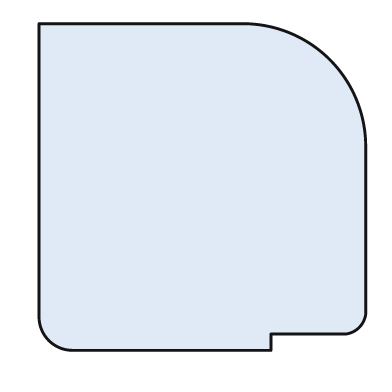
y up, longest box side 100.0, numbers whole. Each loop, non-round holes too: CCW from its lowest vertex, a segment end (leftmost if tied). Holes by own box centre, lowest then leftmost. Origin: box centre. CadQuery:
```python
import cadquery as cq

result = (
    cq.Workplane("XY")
    .moveTo(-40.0, -50.0)
    .lineTo(21.0, -50.0)
    .lineTo(21.0, -45.0)
    .lineTo(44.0, -45.0)
    .threePointArc((48.0, -43.0), (50.0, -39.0))
    .lineTo(50.0, 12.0)
    .threePointArc((39.0, 39.0), (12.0, 50.0))
    .lineTo(-50.0, 50.0)
    .lineTo(-50.0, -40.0)
    .threePointArc((-47.0, -47.0), (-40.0, -50.0))
    .close()
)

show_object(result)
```